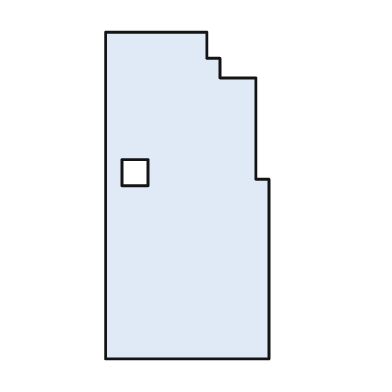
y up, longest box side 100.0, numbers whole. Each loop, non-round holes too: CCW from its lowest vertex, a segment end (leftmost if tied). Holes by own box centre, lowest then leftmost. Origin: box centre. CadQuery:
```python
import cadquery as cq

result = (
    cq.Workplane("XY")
    .moveTo(-25.0, -50.0)
    .lineTo(25.0, -50.0)
    .lineTo(25.0, 5.0)
    .lineTo(21.0, 5.0)
    .lineTo(21.0, 36.0)
    .lineTo(10.0, 36.0)
    .lineTo(10.0, 42.0)
    .lineTo(6.0, 42.0)
    .lineTo(6.0, 50.0)
    .lineTo(-25.0, 50.0)
    .close()
    .moveTo(-20.0, 3.0)
    .lineTo(-12.0, 3.0)
    .lineTo(-12.0, 11.0)
    .lineTo(-20.0, 11.0)
    .close()
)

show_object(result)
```